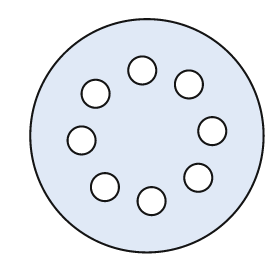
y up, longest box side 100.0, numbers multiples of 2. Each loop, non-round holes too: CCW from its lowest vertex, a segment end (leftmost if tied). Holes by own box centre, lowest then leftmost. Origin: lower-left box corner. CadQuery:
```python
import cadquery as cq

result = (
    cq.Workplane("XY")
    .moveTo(50.0, 50.0)
    .circle(50.0)
    .moveTo(52.0, 22.0)
    .circle(6.0)
    .moveTo(32.0, 28.0)
    .circle(6.0)
    .moveTo(72.0, 32.0)
    .circle(6.0)
    .moveTo(22.0, 48.0)
    .circle(6.0)
    .moveTo(78.0, 52.0)
    .circle(6.0)
    .moveTo(28.0, 68.0)
    .circle(6.0)
    .moveTo(68.0, 72.0)
    .circle(6.0)
    .moveTo(48.0, 78.0)
    .circle(6.0)
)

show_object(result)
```